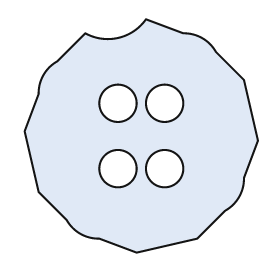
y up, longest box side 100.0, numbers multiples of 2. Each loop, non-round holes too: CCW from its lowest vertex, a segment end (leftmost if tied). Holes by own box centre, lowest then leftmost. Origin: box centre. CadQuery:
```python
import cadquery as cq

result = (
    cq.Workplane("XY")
    .moveTo(-2.0, -50.0)
    .lineTo(24.0, -44.0)
    .lineTo(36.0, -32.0)
    .threePointArc((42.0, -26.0), (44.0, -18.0))
    .lineTo(50.0, -2.0)
    .lineTo(44.0, 24.0)
    .lineTo(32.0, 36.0)
    .threePointArc((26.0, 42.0), (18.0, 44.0))
    .lineTo(2.0, 50.0)
    .threePointArc((-10.0, 42.0), (-24.0, 44.0))
    .lineTo(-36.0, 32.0)
    .threePointArc((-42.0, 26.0), (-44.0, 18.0))
    .lineTo(-50.0, 2.0)
    .lineTo(-44.0, -24.0)
    .lineTo(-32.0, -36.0)
    .threePointArc((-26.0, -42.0), (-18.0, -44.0))
    .close()
    .moveTo(-10.0, -14.0)
    .circle(8.0)
    .moveTo(10.0, -14.0)
    .circle(8.0)
    .moveTo(-10.0, 14.0)
    .circle(8.0)
    .moveTo(10.0, 14.0)
    .circle(8.0)
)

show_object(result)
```